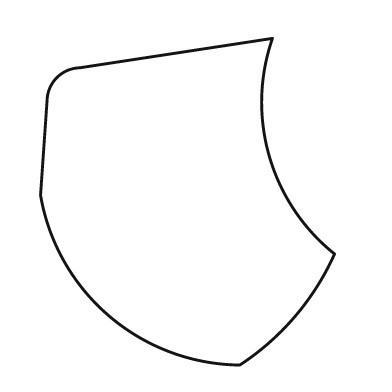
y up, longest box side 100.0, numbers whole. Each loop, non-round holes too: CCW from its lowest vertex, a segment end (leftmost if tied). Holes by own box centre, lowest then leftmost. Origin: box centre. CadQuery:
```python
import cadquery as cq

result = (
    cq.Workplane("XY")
    .moveTo(16.0, -50.0)
    .threePointArc((33.0, -35.0), (45.0, -16.0))
    .threePointArc((25.0, 14.0), (26.0, 50.0))
    .lineTo(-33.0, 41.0)
    .threePointArc((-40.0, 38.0), (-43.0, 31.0))
    .lineTo(-45.0, 2.0)
    .threePointArc((-24.0, -35.0), (16.0, -50.0))
    .close()
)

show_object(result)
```